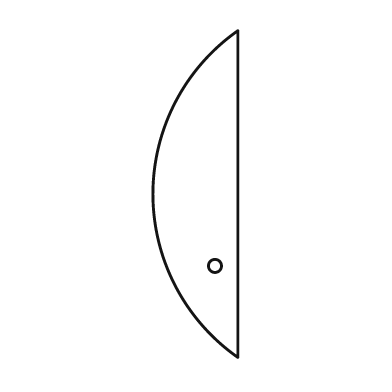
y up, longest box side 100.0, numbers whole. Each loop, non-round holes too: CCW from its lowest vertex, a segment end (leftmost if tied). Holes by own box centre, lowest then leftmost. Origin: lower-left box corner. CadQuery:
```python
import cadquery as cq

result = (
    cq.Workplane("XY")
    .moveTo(26.0, 0.0)
    .lineTo(26.0, 100.0)
    .threePointArc((0.0, 50.0), (26.0, 0.0))
    .close()
    .moveTo(19.0, 28.0)
    .circle(2.0)
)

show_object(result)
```